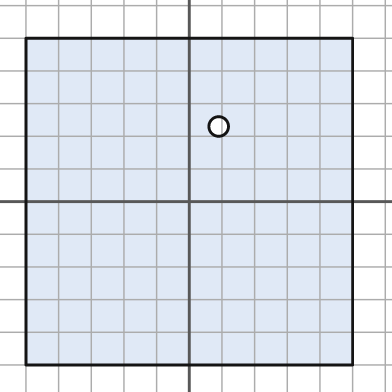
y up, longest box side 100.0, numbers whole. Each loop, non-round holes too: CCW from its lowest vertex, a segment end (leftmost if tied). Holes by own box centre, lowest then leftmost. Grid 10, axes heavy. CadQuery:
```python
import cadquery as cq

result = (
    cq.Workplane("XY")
    .moveTo(-50.0, -50.0)
    .lineTo(50.0, -50.0)
    .lineTo(50.0, 50.0)
    .lineTo(-50.0, 50.0)
    .close()
    .moveTo(9.0, 23.0)
    .circle(3.0)
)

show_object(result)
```